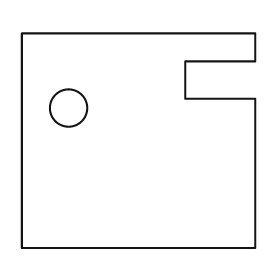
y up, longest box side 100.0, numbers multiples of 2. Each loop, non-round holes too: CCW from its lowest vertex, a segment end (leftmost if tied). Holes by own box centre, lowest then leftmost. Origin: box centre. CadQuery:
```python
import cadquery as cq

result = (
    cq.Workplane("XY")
    .moveTo(-50.0, -46.0)
    .lineTo(50.0, -46.0)
    .lineTo(50.0, 18.0)
    .lineTo(20.0, 18.0)
    .lineTo(20.0, 34.0)
    .lineTo(50.0, 34.0)
    .lineTo(50.0, 46.0)
    .lineTo(-50.0, 46.0)
    .close()
    .moveTo(-30.0, 14.0)
    .circle(8.0)
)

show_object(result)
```